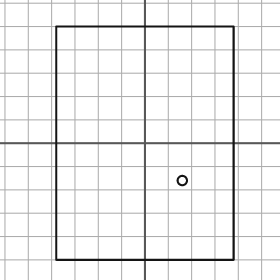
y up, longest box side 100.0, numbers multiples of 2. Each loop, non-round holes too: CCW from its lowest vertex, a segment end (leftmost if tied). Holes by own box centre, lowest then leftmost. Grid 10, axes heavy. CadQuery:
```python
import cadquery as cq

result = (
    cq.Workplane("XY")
    .moveTo(-38.0, -50.0)
    .lineTo(38.0, -50.0)
    .lineTo(38.0, 50.0)
    .lineTo(-38.0, 50.0)
    .close()
    .moveTo(16.0, -16.0)
    .circle(2.0)
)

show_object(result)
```